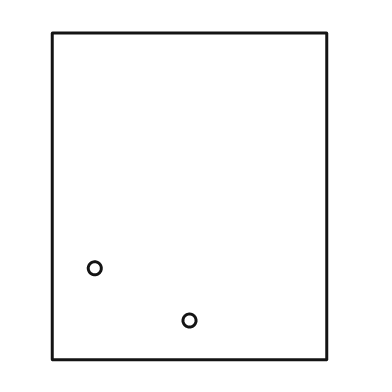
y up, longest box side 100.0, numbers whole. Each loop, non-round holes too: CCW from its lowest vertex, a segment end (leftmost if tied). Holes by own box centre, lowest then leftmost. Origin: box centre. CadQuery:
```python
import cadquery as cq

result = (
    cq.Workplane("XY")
    .moveTo(-42.0, -50.0)
    .lineTo(42.0, -50.0)
    .lineTo(42.0, 50.0)
    .lineTo(-42.0, 50.0)
    .close()
    .moveTo(0.0, -38.0)
    .circle(2.0)
    .moveTo(-29.0, -22.0)
    .circle(2.0)
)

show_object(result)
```